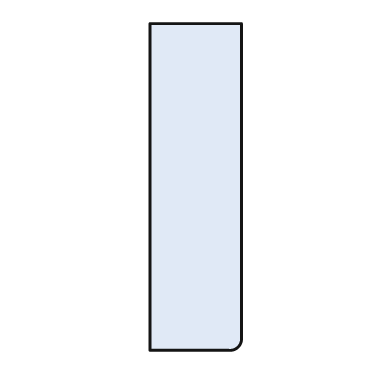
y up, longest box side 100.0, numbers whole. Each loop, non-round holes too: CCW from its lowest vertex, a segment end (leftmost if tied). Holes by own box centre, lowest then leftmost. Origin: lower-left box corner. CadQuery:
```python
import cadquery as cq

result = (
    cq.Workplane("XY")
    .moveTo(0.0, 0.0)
    .lineTo(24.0, 0.0)
    .threePointArc((27.0, 1.0), (28.0, 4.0))
    .lineTo(28.0, 100.0)
    .lineTo(0.0, 100.0)
    .close()
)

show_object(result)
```